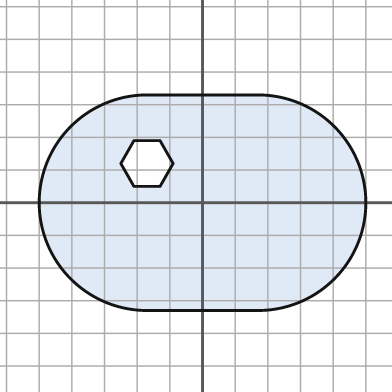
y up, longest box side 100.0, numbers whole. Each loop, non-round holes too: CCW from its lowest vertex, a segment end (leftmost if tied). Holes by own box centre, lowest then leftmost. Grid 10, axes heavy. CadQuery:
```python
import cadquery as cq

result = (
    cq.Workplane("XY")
    .moveTo(-17.0, -33.0)
    .lineTo(17.0, -33.0)
    .threePointArc((50.0, 0.0), (17.0, 33.0))
    .lineTo(-17.0, 33.0)
    .threePointArc((-50.0, 0.0), (-17.0, -33.0))
    .close()
    .moveTo(-21.0, 5.0)
    .lineTo(-13.0, 5.0)
    .lineTo(-9.0, 12.0)
    .lineTo(-13.0, 19.0)
    .lineTo(-21.0, 19.0)
    .lineTo(-25.0, 12.0)
    .close()
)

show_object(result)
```